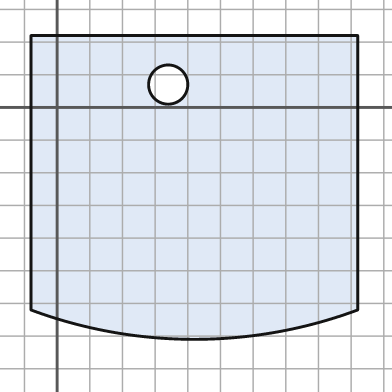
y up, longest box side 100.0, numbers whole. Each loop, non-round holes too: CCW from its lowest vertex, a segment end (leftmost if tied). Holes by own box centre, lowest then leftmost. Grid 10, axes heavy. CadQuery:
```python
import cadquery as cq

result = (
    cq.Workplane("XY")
    .moveTo(-8.0, -62.0)
    .threePointArc((42.0, -71.0), (92.0, -62.0))
    .lineTo(92.0, 22.0)
    .lineTo(-8.0, 22.0)
    .close()
    .moveTo(34.0, 7.0)
    .circle(6.0)
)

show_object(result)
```